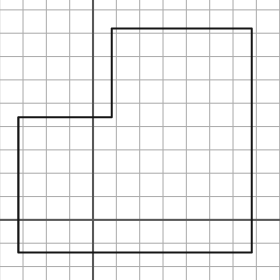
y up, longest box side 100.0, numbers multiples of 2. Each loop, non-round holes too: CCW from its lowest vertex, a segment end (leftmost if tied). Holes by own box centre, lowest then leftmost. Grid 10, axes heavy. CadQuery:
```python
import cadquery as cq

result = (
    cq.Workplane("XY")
    .moveTo(-32.0, -14.0)
    .lineTo(68.0, -14.0)
    .lineTo(68.0, 82.0)
    .lineTo(8.0, 82.0)
    .lineTo(8.0, 44.0)
    .lineTo(-32.0, 44.0)
    .close()
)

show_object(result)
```